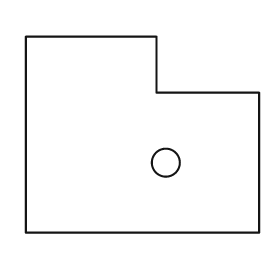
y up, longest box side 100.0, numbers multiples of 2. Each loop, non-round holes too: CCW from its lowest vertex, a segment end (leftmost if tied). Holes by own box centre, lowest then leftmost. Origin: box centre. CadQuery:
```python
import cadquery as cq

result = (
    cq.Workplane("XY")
    .moveTo(-50.0, -42.0)
    .lineTo(50.0, -42.0)
    .lineTo(50.0, 18.0)
    .lineTo(6.0, 18.0)
    .lineTo(6.0, 42.0)
    .lineTo(-50.0, 42.0)
    .close()
    .moveTo(10.0, -12.0)
    .circle(6.0)
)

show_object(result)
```